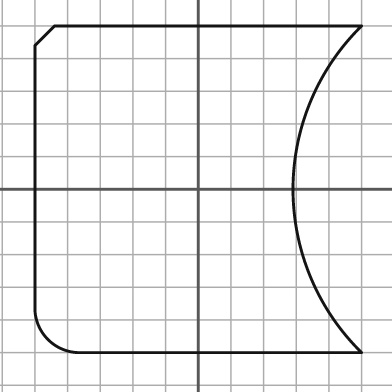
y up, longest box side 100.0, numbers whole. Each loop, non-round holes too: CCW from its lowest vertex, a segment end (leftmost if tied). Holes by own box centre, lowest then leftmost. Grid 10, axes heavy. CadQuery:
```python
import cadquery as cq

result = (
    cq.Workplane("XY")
    .moveTo(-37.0, -50.0)
    .lineTo(50.0, -50.0)
    .threePointArc((29.0, 0.0), (50.0, 50.0))
    .lineTo(-44.0, 50.0)
    .lineTo(-50.0, 44.0)
    .lineTo(-50.0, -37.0)
    .threePointArc((-46.0, -46.0), (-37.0, -50.0))
    .close()
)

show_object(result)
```